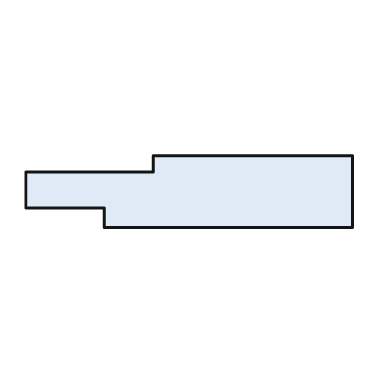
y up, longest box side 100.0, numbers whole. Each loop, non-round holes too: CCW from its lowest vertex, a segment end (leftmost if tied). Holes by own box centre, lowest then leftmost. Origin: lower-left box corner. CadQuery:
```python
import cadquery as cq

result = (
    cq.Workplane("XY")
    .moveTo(24.0, 0.0)
    .lineTo(100.0, 0.0)
    .lineTo(100.0, 22.0)
    .lineTo(39.0, 22.0)
    .lineTo(39.0, 17.0)
    .lineTo(0.0, 17.0)
    .lineTo(0.0, 6.0)
    .lineTo(24.0, 6.0)
    .close()
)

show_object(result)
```